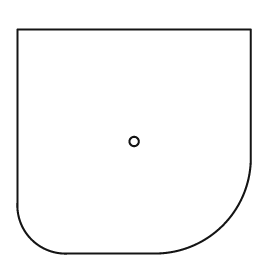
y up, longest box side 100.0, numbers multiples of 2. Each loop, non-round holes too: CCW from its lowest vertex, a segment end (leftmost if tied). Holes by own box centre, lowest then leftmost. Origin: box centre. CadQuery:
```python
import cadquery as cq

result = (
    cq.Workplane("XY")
    .moveTo(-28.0, -48.0)
    .lineTo(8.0, -48.0)
    .threePointArc((38.0, -36.0), (50.0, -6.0))
    .lineTo(50.0, 48.0)
    .lineTo(-50.0, 48.0)
    .lineTo(-50.0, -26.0)
    .threePointArc((-44.0, -42.0), (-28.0, -48.0))
    .close()
    .moveTo(0.0, 0.0)
    .circle(2.0)
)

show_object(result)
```